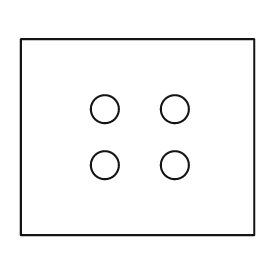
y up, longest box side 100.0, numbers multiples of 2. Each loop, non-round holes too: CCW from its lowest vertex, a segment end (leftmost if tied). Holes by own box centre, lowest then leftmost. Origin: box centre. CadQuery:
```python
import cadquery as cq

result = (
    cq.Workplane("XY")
    .moveTo(-50.0, -42.0)
    .lineTo(50.0, -42.0)
    .lineTo(50.0, 42.0)
    .lineTo(-50.0, 42.0)
    .close()
    .moveTo(-14.0, -12.0)
    .circle(6.0)
    .moveTo(16.0, -12.0)
    .circle(6.0)
    .moveTo(-14.0, 12.0)
    .circle(6.0)
    .moveTo(16.0, 12.0)
    .circle(6.0)
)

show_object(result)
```